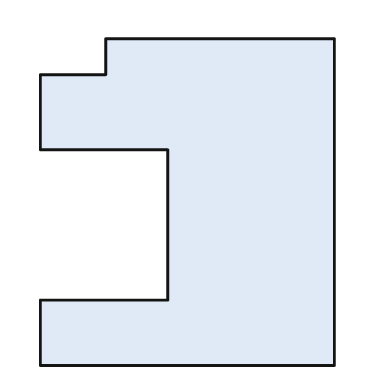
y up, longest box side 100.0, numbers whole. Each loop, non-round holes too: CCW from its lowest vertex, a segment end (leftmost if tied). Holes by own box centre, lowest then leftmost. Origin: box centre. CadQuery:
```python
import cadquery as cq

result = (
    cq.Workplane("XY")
    .moveTo(-45.0, -50.0)
    .lineTo(45.0, -50.0)
    .lineTo(45.0, 50.0)
    .lineTo(-25.0, 50.0)
    .lineTo(-25.0, 39.0)
    .lineTo(-45.0, 39.0)
    .lineTo(-45.0, 16.0)
    .lineTo(-6.0, 16.0)
    .lineTo(-6.0, -30.0)
    .lineTo(-45.0, -30.0)
    .close()
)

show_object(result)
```